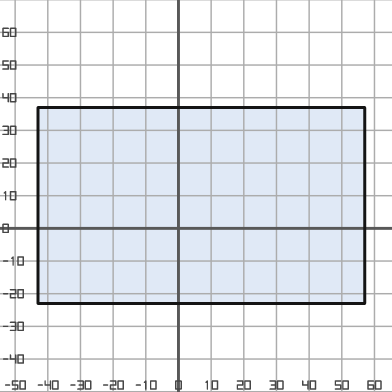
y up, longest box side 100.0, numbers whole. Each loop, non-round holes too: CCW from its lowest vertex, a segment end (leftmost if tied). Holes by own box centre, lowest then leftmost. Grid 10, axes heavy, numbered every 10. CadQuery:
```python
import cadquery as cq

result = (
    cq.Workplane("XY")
    .moveTo(-43.0, -23.0)
    .lineTo(57.0, -23.0)
    .lineTo(57.0, 37.0)
    .lineTo(-43.0, 37.0)
    .close()
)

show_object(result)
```